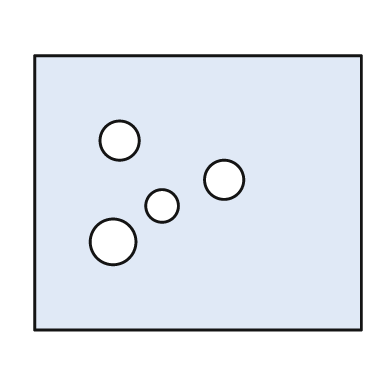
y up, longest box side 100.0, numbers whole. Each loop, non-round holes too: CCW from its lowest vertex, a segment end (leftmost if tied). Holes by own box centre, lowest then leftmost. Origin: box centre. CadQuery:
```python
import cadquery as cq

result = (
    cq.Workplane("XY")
    .moveTo(-50.0, -42.0)
    .lineTo(50.0, -42.0)
    .lineTo(50.0, 42.0)
    .lineTo(-50.0, 42.0)
    .close()
    .moveTo(-26.0, -15.0)
    .circle(7.0)
    .moveTo(-11.0, -4.0)
    .circle(5.0)
    .moveTo(8.0, 4.0)
    .circle(6.0)
    .moveTo(-24.0, 16.0)
    .circle(6.0)
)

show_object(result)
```